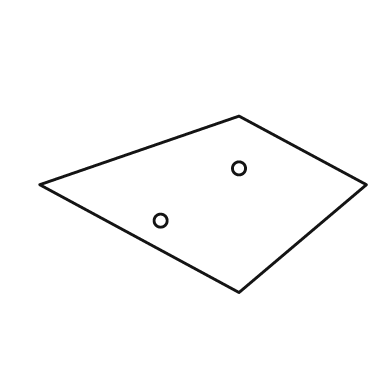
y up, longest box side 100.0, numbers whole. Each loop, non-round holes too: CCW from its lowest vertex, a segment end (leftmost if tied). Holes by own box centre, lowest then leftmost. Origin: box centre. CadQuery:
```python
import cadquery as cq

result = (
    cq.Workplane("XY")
    .moveTo(11.0, -27.0)
    .lineTo(50.0, 6.0)
    .lineTo(11.0, 27.0)
    .lineTo(-50.0, 6.0)
    .close()
    .moveTo(-13.0, -5.0)
    .circle(2.0)
    .moveTo(11.0, 11.0)
    .circle(2.0)
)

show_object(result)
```